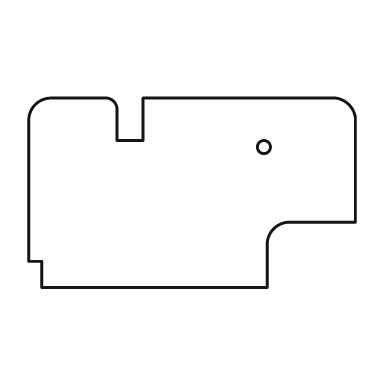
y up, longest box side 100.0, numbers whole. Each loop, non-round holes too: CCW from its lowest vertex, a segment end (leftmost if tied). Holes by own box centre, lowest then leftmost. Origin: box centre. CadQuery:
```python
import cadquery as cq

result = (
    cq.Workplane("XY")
    .moveTo(-46.0, -29.0)
    .lineTo(23.0, -29.0)
    .lineTo(23.0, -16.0)
    .threePointArc((25.0, -11.0), (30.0, -9.0))
    .lineTo(50.0, -9.0)
    .lineTo(50.0, 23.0)
    .threePointArc((48.0, 27.0), (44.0, 29.0))
    .lineTo(-15.0, 29.0)
    .lineTo(-15.0, 16.0)
    .lineTo(-23.0, 16.0)
    .lineTo(-23.0, 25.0)
    .threePointArc((-24.0, 28.0), (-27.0, 29.0))
    .lineTo(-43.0, 29.0)
    .threePointArc((-48.0, 27.0), (-50.0, 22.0))
    .lineTo(-50.0, -21.0)
    .lineTo(-46.0, -21.0)
    .close()
    .moveTo(22.0, 14.0)
    .circle(2.0)
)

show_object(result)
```